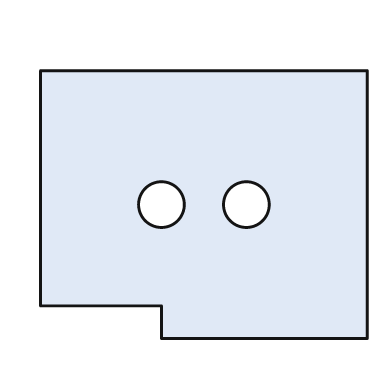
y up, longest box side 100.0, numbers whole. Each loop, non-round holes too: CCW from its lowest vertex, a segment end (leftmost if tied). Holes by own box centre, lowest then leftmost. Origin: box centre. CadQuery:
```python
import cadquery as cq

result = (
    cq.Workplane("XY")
    .moveTo(-13.0, -41.0)
    .lineTo(50.0, -41.0)
    .lineTo(50.0, 41.0)
    .lineTo(-50.0, 41.0)
    .lineTo(-50.0, -31.0)
    .lineTo(-13.0, -31.0)
    .close()
    .moveTo(-13.0, 0.0)
    .circle(7.0)
    .moveTo(13.0, 0.0)
    .circle(7.0)
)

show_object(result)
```